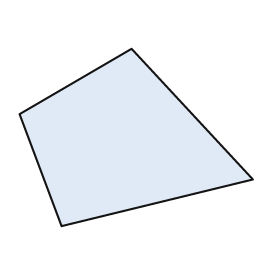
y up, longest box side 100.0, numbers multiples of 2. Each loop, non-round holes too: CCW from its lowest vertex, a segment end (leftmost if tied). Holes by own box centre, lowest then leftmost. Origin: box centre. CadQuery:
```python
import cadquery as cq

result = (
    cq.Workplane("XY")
    .moveTo(-32.0, -38.0)
    .lineTo(50.0, -18.0)
    .lineTo(-2.0, 38.0)
    .lineTo(-50.0, 10.0)
    .close()
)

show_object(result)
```